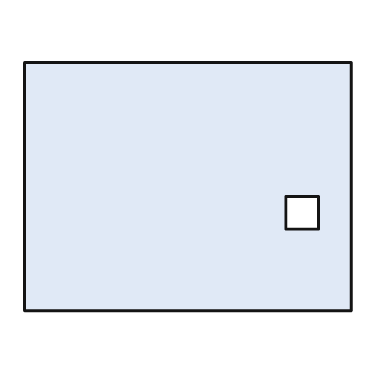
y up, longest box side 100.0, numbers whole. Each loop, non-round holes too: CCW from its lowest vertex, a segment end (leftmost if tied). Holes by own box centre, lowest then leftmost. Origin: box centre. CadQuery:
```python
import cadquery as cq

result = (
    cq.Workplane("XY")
    .moveTo(-50.0, -38.0)
    .lineTo(50.0, -38.0)
    .lineTo(50.0, 38.0)
    .lineTo(-50.0, 38.0)
    .close()
    .moveTo(30.0, -13.0)
    .lineTo(40.0, -13.0)
    .lineTo(40.0, -3.0)
    .lineTo(30.0, -3.0)
    .close()
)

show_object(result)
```